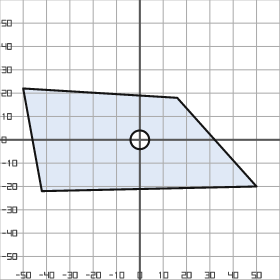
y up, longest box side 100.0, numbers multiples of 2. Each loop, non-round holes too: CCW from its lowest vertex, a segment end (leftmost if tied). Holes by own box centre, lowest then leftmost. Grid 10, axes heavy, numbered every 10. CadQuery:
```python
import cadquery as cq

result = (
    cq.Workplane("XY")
    .moveTo(-42.0, -22.0)
    .lineTo(50.0, -20.0)
    .lineTo(16.0, 18.0)
    .lineTo(-50.0, 22.0)
    .close()
    .moveTo(0.0, 0.0)
    .circle(4.0)
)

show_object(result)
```